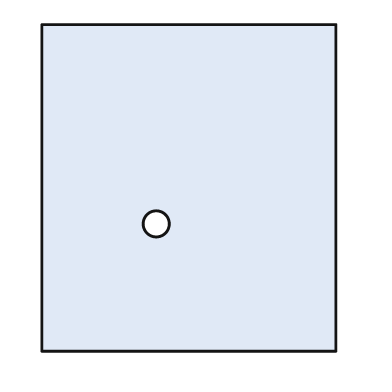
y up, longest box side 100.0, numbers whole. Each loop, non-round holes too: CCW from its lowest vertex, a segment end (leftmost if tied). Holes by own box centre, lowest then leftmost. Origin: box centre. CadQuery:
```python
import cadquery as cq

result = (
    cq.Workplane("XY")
    .moveTo(-45.0, -50.0)
    .lineTo(45.0, -50.0)
    .lineTo(45.0, 50.0)
    .lineTo(-45.0, 50.0)
    .close()
    .moveTo(-10.0, -11.0)
    .circle(4.0)
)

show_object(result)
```